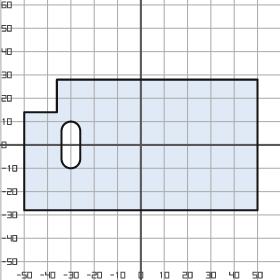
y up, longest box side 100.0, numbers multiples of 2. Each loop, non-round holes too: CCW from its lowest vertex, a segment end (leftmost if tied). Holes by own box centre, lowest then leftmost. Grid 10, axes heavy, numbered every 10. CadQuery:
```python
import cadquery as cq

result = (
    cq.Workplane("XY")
    .moveTo(-50.0, -28.0)
    .lineTo(50.0, -28.0)
    .lineTo(50.0, 28.0)
    .lineTo(-36.0, 28.0)
    .lineTo(-36.0, 14.0)
    .lineTo(-50.0, 14.0)
    .close()
    .moveTo(-34.0, -6.0)
    .threePointArc((-30.0, -10.0), (-26.0, -6.0))
    .lineTo(-26.0, 6.0)
    .threePointArc((-30.0, 10.0), (-34.0, 6.0))
    .close()
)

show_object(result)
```